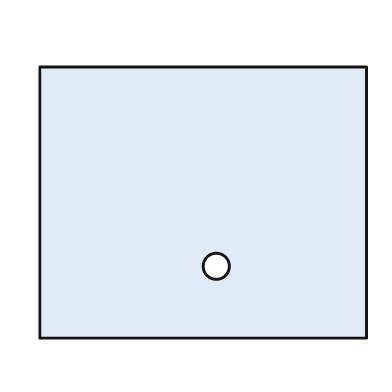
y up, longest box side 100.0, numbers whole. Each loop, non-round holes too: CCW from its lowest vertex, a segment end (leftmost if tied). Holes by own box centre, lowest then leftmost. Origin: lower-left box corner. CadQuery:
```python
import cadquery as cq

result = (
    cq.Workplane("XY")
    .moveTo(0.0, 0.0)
    .lineTo(100.0, 0.0)
    .lineTo(100.0, 83.0)
    .lineTo(0.0, 83.0)
    .close()
    .moveTo(54.0, 22.0)
    .circle(4.0)
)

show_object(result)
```